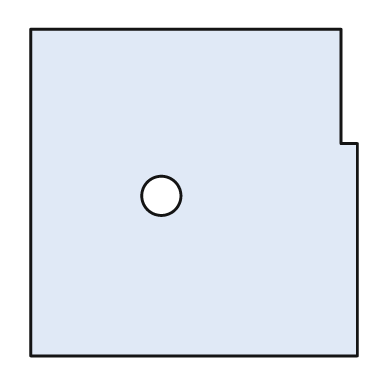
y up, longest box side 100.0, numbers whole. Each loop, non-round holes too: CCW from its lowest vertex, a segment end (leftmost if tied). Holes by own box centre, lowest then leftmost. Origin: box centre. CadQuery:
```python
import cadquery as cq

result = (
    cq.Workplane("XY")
    .moveTo(-50.0, -50.0)
    .lineTo(50.0, -50.0)
    .lineTo(50.0, 15.0)
    .lineTo(45.0, 15.0)
    .lineTo(45.0, 50.0)
    .lineTo(-50.0, 50.0)
    .close()
    .moveTo(-10.0, -1.0)
    .circle(6.0)
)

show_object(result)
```